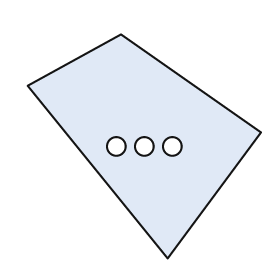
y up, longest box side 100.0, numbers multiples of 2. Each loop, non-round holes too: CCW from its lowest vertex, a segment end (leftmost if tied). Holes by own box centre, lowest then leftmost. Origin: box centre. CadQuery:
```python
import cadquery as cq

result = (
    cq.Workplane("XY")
    .moveTo(10.0, -48.0)
    .lineTo(50.0, 6.0)
    .lineTo(-10.0, 48.0)
    .lineTo(-50.0, 26.0)
    .close()
    .moveTo(-12.0, 0.0)
    .circle(4.0)
    .moveTo(0.0, 0.0)
    .circle(4.0)
    .moveTo(12.0, 0.0)
    .circle(4.0)
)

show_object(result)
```